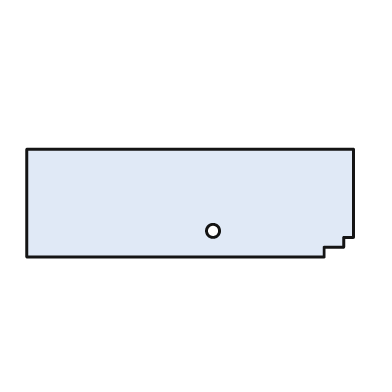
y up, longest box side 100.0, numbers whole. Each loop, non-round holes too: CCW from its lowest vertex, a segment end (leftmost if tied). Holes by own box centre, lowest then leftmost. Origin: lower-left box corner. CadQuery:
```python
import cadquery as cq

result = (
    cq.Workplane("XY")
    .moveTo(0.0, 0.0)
    .lineTo(91.0, 0.0)
    .lineTo(91.0, 3.0)
    .lineTo(97.0, 3.0)
    .lineTo(97.0, 6.0)
    .lineTo(100.0, 6.0)
    .lineTo(100.0, 33.0)
    .lineTo(0.0, 33.0)
    .close()
    .moveTo(57.0, 8.0)
    .circle(2.0)
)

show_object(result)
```